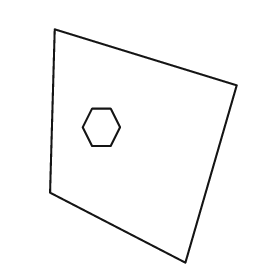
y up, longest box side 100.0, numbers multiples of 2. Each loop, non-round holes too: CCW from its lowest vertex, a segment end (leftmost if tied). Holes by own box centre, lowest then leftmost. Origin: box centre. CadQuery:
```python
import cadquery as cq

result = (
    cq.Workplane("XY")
    .moveTo(18.0, -50.0)
    .lineTo(40.0, 26.0)
    .lineTo(-38.0, 50.0)
    .lineTo(-40.0, -20.0)
    .close()
    .moveTo(-22.0, 0.0)
    .lineTo(-14.0, 0.0)
    .lineTo(-10.0, 8.0)
    .lineTo(-14.0, 16.0)
    .lineTo(-22.0, 16.0)
    .lineTo(-26.0, 8.0)
    .close()
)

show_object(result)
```